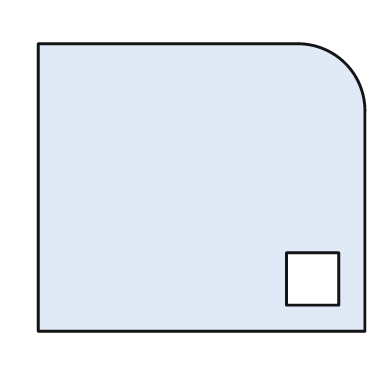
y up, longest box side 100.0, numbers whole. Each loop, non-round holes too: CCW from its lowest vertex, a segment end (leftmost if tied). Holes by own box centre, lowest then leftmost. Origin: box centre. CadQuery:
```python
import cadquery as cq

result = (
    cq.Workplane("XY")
    .moveTo(-50.0, -44.0)
    .lineTo(50.0, -44.0)
    .lineTo(50.0, 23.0)
    .threePointArc((44.0, 38.0), (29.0, 44.0))
    .lineTo(-50.0, 44.0)
    .close()
    .moveTo(26.0, -36.0)
    .lineTo(42.0, -36.0)
    .lineTo(42.0, -20.0)
    .lineTo(26.0, -20.0)
    .close()
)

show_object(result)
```